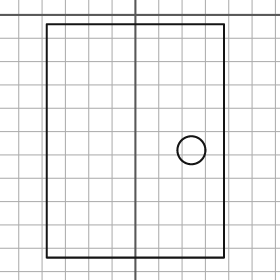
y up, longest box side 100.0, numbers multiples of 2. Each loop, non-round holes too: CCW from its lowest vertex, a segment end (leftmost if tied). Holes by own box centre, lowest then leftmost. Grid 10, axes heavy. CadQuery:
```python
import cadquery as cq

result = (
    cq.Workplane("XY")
    .moveTo(-38.0, -104.0)
    .lineTo(38.0, -104.0)
    .lineTo(38.0, -4.0)
    .lineTo(-38.0, -4.0)
    .close()
    .moveTo(24.0, -58.0)
    .circle(6.0)
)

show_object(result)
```